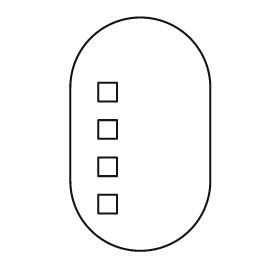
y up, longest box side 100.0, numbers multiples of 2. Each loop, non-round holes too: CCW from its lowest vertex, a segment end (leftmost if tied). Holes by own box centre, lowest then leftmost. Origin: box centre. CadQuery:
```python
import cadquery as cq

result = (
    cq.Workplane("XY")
    .moveTo(-30.0, -20.0)
    .threePointArc((0.0, -50.0), (30.0, -20.0))
    .lineTo(30.0, 20.0)
    .threePointArc((0.0, 50.0), (-30.0, 20.0))
    .close()
    .moveTo(-18.0, -34.0)
    .lineTo(-10.0, -34.0)
    .lineTo(-10.0, -26.0)
    .lineTo(-18.0, -26.0)
    .close()
    .moveTo(-18.0, -18.0)
    .lineTo(-10.0, -18.0)
    .lineTo(-10.0, -10.0)
    .lineTo(-18.0, -10.0)
    .close()
    .moveTo(-18.0, -2.0)
    .lineTo(-10.0, -2.0)
    .lineTo(-10.0, 6.0)
    .lineTo(-18.0, 6.0)
    .close()
    .moveTo(-18.0, 14.0)
    .lineTo(-10.0, 14.0)
    .lineTo(-10.0, 22.0)
    .lineTo(-18.0, 22.0)
    .close()
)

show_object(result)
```